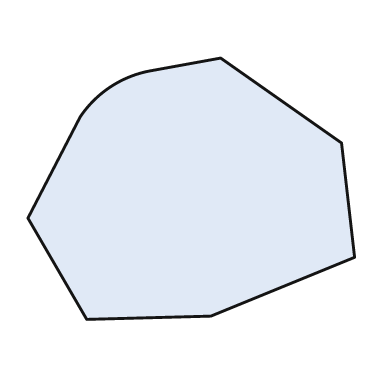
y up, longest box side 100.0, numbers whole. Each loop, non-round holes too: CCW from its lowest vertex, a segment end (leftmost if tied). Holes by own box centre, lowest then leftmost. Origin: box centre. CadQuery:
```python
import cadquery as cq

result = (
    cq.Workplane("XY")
    .moveTo(-32.0, -40.0)
    .lineTo(6.0, -39.0)
    .lineTo(50.0, -21.0)
    .lineTo(46.0, 14.0)
    .lineTo(9.0, 40.0)
    .lineTo(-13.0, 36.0)
    .threePointArc((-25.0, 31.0), (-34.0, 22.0))
    .lineTo(-50.0, -9.0)
    .close()
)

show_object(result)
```